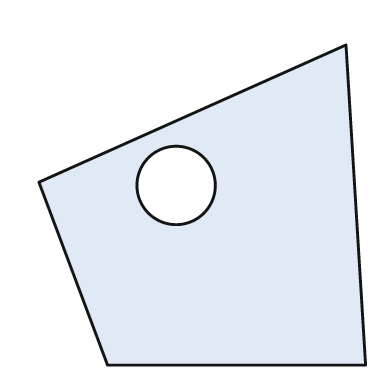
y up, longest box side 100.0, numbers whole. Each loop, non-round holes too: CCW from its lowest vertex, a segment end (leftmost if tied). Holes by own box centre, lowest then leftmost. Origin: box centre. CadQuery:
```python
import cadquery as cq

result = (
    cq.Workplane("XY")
    .moveTo(-29.0, -49.0)
    .lineTo(50.0, -49.0)
    .lineTo(44.0, 49.0)
    .lineTo(-50.0, 7.0)
    .close()
    .moveTo(-8.0, 6.0)
    .circle(12.0)
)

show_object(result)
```